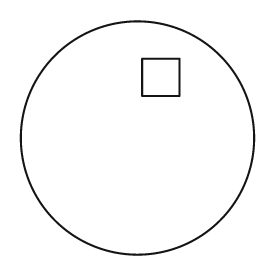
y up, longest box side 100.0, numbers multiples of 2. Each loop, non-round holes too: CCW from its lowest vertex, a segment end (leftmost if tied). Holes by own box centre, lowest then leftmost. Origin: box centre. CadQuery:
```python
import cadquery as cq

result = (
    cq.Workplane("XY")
    .moveTo(0.0, 0.0)
    .circle(50.0)
    .moveTo(2.0, 18.0)
    .lineTo(18.0, 18.0)
    .lineTo(18.0, 34.0)
    .lineTo(2.0, 34.0)
    .close()
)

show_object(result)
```